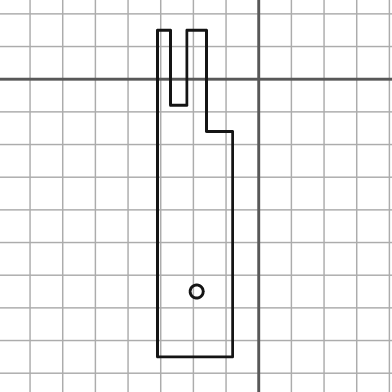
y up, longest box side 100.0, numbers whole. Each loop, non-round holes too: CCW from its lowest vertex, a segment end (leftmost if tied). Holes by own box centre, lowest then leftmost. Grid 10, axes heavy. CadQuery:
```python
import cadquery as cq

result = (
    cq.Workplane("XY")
    .moveTo(-31.0, -85.0)
    .lineTo(-8.0, -85.0)
    .lineTo(-8.0, -16.0)
    .lineTo(-16.0, -16.0)
    .lineTo(-16.0, 15.0)
    .lineTo(-22.0, 15.0)
    .lineTo(-22.0, -8.0)
    .lineTo(-27.0, -8.0)
    .lineTo(-27.0, 15.0)
    .lineTo(-31.0, 15.0)
    .close()
    .moveTo(-19.0, -65.0)
    .circle(2.0)
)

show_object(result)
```